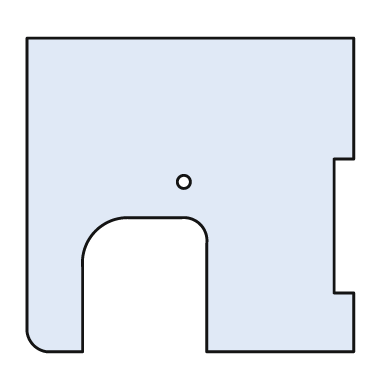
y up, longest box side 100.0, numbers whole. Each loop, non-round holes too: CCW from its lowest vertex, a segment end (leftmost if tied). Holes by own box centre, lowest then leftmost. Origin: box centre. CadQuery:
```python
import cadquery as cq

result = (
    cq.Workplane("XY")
    .moveTo(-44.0, -48.0)
    .lineTo(-33.0, -48.0)
    .lineTo(-33.0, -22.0)
    .threePointArc((-29.0, -11.0), (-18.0, -7.0))
    .lineTo(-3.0, -7.0)
    .threePointArc((3.0, -9.0), (5.0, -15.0))
    .lineTo(5.0, -48.0)
    .lineTo(50.0, -48.0)
    .lineTo(50.0, -30.0)
    .lineTo(44.0, -30.0)
    .lineTo(44.0, 11.0)
    .lineTo(50.0, 11.0)
    .lineTo(50.0, 48.0)
    .lineTo(-50.0, 48.0)
    .lineTo(-50.0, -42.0)
    .threePointArc((-48.0, -46.0), (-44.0, -48.0))
    .close()
    .moveTo(-2.0, 4.0)
    .circle(2.0)
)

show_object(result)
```